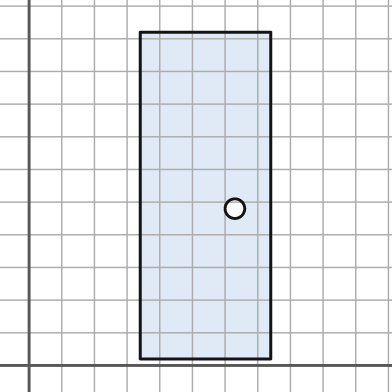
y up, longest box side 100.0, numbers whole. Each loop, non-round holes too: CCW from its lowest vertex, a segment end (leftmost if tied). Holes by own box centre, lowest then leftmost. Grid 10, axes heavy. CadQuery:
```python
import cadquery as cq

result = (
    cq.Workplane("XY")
    .moveTo(34.0, 2.0)
    .lineTo(74.0, 2.0)
    .lineTo(74.0, 102.0)
    .lineTo(34.0, 102.0)
    .close()
    .moveTo(63.0, 48.0)
    .circle(3.0)
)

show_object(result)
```